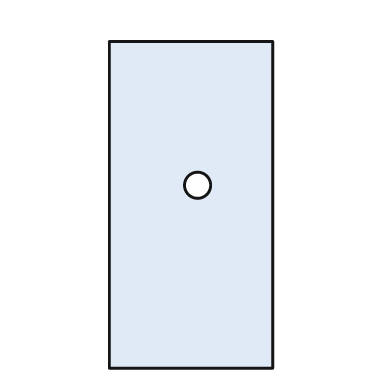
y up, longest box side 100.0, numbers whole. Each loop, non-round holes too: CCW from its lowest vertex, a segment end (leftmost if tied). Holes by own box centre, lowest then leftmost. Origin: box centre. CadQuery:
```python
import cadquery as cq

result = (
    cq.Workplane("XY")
    .moveTo(-25.0, -50.0)
    .lineTo(25.0, -50.0)
    .lineTo(25.0, 50.0)
    .lineTo(-25.0, 50.0)
    .close()
    .moveTo(2.0, 6.0)
    .circle(4.0)
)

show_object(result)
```